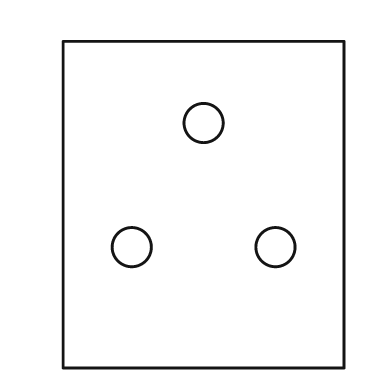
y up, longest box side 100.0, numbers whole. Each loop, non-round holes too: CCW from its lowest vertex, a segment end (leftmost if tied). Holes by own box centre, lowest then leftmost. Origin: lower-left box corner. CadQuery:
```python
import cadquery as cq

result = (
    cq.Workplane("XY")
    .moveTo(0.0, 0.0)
    .lineTo(86.0, 0.0)
    .lineTo(86.0, 100.0)
    .lineTo(0.0, 100.0)
    .close()
    .moveTo(21.0, 37.0)
    .circle(6.0)
    .moveTo(65.0, 37.0)
    .circle(6.0)
    .moveTo(43.0, 75.0)
    .circle(6.0)
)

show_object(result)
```